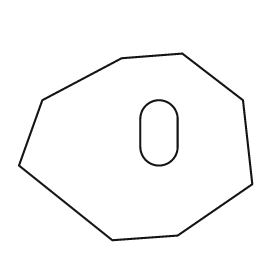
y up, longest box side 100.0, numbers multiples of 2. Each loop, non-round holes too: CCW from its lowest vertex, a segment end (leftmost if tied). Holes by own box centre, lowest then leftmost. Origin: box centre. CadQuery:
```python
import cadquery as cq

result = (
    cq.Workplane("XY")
    .moveTo(-10.0, -40.0)
    .lineTo(18.0, -38.0)
    .lineTo(50.0, -16.0)
    .lineTo(46.0, 20.0)
    .lineTo(20.0, 40.0)
    .lineTo(-6.0, 38.0)
    .lineTo(-40.0, 20.0)
    .lineTo(-50.0, -8.0)
    .close()
    .moveTo(2.0, 0.0)
    .threePointArc((10.0, -8.0), (18.0, 0.0))
    .lineTo(18.0, 12.0)
    .threePointArc((10.0, 20.0), (2.0, 12.0))
    .close()
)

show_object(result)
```